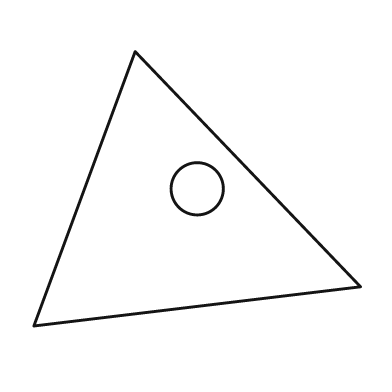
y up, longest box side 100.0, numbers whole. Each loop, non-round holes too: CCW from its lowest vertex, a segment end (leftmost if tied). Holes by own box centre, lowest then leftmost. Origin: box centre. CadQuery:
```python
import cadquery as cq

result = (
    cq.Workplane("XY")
    .moveTo(-50.0, -42.0)
    .lineTo(50.0, -30.0)
    .lineTo(-19.0, 42.0)
    .close()
    .moveTo(0.0, 0.0)
    .circle(8.0)
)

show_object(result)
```